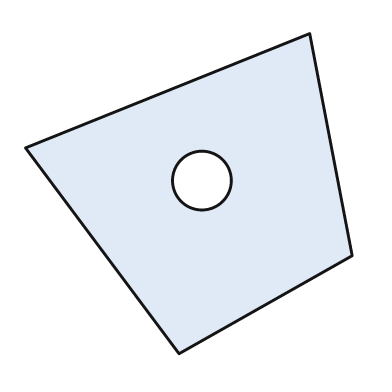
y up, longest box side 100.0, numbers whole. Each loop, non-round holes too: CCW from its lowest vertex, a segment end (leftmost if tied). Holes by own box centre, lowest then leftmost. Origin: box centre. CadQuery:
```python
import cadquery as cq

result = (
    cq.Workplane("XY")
    .moveTo(-3.0, -49.0)
    .lineTo(50.0, -19.0)
    .lineTo(37.0, 49.0)
    .lineTo(-50.0, 14.0)
    .close()
    .moveTo(4.0, 4.0)
    .circle(9.0)
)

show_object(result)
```